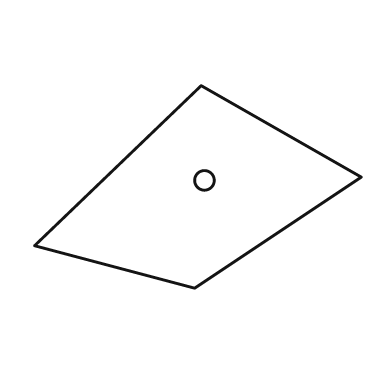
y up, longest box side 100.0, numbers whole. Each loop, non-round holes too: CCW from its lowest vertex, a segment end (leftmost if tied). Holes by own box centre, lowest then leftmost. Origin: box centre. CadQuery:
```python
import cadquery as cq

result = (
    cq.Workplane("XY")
    .moveTo(-1.0, -31.0)
    .lineTo(50.0, 3.0)
    .lineTo(1.0, 31.0)
    .lineTo(-50.0, -18.0)
    .close()
    .moveTo(2.0, 2.0)
    .circle(3.0)
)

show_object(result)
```